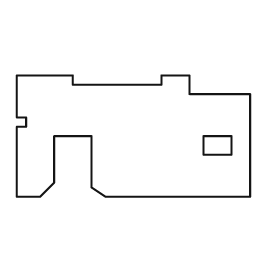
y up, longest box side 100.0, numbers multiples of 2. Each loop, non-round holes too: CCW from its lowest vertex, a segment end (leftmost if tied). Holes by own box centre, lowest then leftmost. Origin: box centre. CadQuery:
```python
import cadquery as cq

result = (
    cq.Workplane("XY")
    .moveTo(-50.0, -26.0)
    .lineTo(-40.0, -26.0)
    .lineTo(-34.0, -20.0)
    .lineTo(-34.0, 0.0)
    .lineTo(-18.0, 0.0)
    .lineTo(-18.0, -22.0)
    .lineTo(-12.0, -26.0)
    .lineTo(50.0, -26.0)
    .lineTo(50.0, 18.0)
    .lineTo(24.0, 18.0)
    .lineTo(24.0, 26.0)
    .lineTo(12.0, 26.0)
    .lineTo(12.0, 22.0)
    .lineTo(-26.0, 22.0)
    .lineTo(-26.0, 26.0)
    .lineTo(-50.0, 26.0)
    .lineTo(-50.0, 8.0)
    .lineTo(-46.0, 8.0)
    .lineTo(-46.0, 4.0)
    .lineTo(-50.0, 4.0)
    .close()
    .moveTo(30.0, -8.0)
    .lineTo(42.0, -8.0)
    .lineTo(42.0, 0.0)
    .lineTo(30.0, 0.0)
    .close()
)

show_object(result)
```